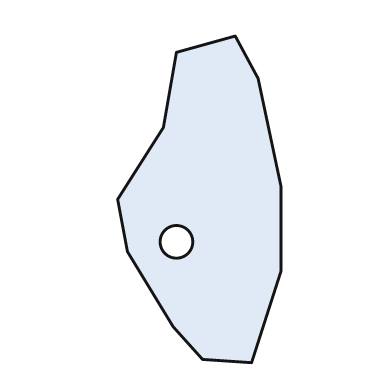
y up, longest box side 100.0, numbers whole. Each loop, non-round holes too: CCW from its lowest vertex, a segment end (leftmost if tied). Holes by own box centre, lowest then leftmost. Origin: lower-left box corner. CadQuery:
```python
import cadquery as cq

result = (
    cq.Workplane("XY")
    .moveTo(41.0, 0.0)
    .lineTo(50.0, 28.0)
    .lineTo(50.0, 54.0)
    .lineTo(43.0, 87.0)
    .lineTo(36.0, 100.0)
    .lineTo(18.0, 95.0)
    .lineTo(14.0, 72.0)
    .lineTo(0.0, 50.0)
    .lineTo(3.0, 34.0)
    .lineTo(17.0, 11.0)
    .lineTo(26.0, 1.0)
    .close()
    .moveTo(18.0, 37.0)
    .circle(5.0)
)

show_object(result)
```